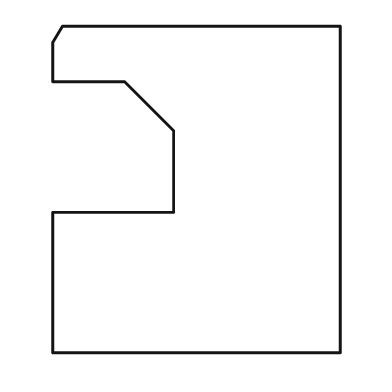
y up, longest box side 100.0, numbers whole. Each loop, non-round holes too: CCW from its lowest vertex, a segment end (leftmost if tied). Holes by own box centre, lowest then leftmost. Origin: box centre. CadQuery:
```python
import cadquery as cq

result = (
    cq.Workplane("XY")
    .moveTo(-44.0, -50.0)
    .lineTo(44.0, -50.0)
    .lineTo(44.0, 50.0)
    .lineTo(-41.0, 50.0)
    .lineTo(-44.0, 45.0)
    .lineTo(-44.0, 33.0)
    .lineTo(-22.0, 33.0)
    .lineTo(-7.0, 18.0)
    .lineTo(-7.0, -7.0)
    .lineTo(-44.0, -7.0)
    .close()
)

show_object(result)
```